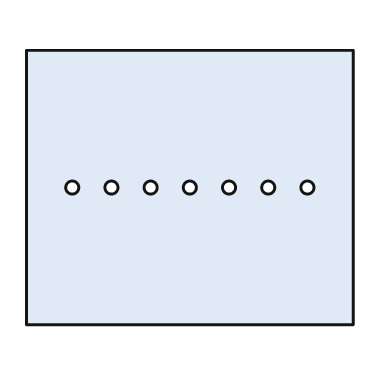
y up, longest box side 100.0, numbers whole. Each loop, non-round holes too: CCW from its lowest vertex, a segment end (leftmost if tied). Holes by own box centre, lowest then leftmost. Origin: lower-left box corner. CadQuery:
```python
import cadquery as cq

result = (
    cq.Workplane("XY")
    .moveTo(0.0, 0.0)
    .lineTo(100.0, 0.0)
    .lineTo(100.0, 84.0)
    .lineTo(0.0, 84.0)
    .close()
    .moveTo(14.0, 42.0)
    .circle(2.0)
    .moveTo(26.0, 42.0)
    .circle(2.0)
    .moveTo(38.0, 42.0)
    .circle(2.0)
    .moveTo(50.0, 42.0)
    .circle(2.0)
    .moveTo(62.0, 42.0)
    .circle(2.0)
    .moveTo(74.0, 42.0)
    .circle(2.0)
    .moveTo(86.0, 42.0)
    .circle(2.0)
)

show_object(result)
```